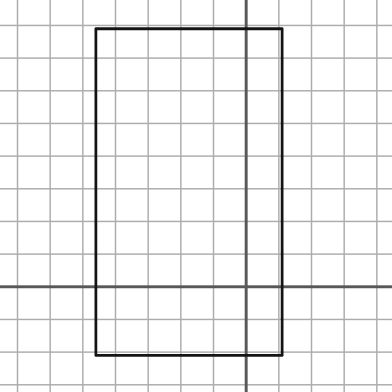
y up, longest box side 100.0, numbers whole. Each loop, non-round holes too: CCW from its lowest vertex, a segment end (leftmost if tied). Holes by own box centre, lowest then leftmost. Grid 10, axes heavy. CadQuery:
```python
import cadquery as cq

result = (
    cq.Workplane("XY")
    .moveTo(-46.0, -21.0)
    .lineTo(11.0, -21.0)
    .lineTo(11.0, 79.0)
    .lineTo(-46.0, 79.0)
    .close()
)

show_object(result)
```